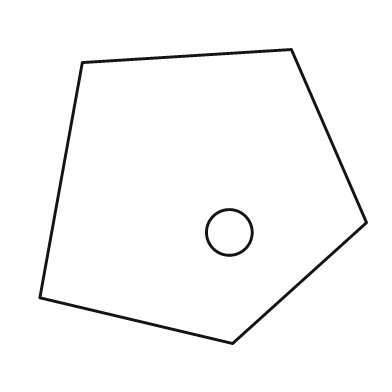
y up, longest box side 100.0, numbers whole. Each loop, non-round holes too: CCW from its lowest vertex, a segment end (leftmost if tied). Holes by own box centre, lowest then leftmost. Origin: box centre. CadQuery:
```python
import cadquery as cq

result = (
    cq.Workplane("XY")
    .moveTo(9.0, -45.0)
    .lineTo(50.0, -8.0)
    .lineTo(27.0, 45.0)
    .lineTo(-37.0, 41.0)
    .lineTo(-50.0, -31.0)
    .close()
    .moveTo(8.0, -11.0)
    .circle(7.0)
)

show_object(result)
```